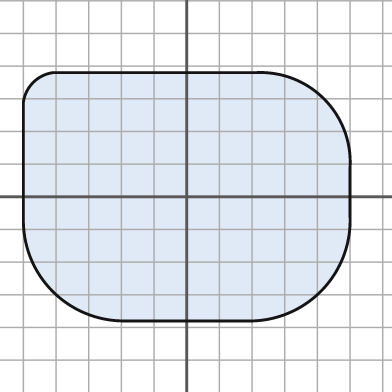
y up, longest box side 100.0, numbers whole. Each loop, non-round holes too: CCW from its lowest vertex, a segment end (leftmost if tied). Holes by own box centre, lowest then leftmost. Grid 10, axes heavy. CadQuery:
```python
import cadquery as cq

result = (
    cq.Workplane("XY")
    .moveTo(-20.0, -38.0)
    .lineTo(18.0, -38.0)
    .threePointArc((41.0, -29.0), (50.0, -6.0))
    .lineTo(50.0, 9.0)
    .threePointArc((42.0, 30.0), (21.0, 38.0))
    .lineTo(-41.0, 38.0)
    .threePointArc((-47.0, 35.0), (-50.0, 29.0))
    .lineTo(-50.0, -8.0)
    .threePointArc((-41.0, -29.0), (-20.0, -38.0))
    .close()
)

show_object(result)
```